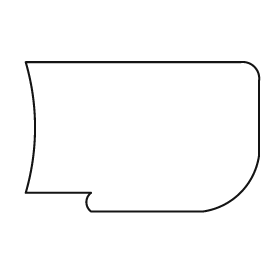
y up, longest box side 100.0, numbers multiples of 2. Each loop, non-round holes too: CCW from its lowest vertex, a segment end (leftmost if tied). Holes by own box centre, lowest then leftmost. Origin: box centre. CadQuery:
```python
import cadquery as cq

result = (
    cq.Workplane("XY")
    .moveTo(-22.0, -32.0)
    .lineTo(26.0, -32.0)
    .threePointArc((42.0, -24.0), (50.0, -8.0))
    .lineTo(50.0, 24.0)
    .threePointArc((48.0, 30.0), (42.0, 32.0))
    .lineTo(-50.0, 32.0)
    .threePointArc((-46.0, 4.0), (-50.0, -24.0))
    .lineTo(-22.0, -24.0)
    .threePointArc((-24.0, -28.0), (-22.0, -32.0))
    .close()
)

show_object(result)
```